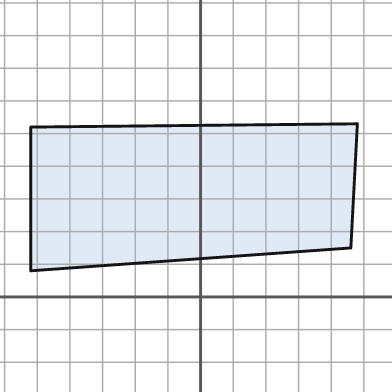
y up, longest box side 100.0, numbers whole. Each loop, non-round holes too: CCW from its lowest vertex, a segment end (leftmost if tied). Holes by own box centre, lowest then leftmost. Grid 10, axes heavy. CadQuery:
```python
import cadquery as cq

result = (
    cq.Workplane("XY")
    .moveTo(-52.0, 8.0)
    .lineTo(46.0, 15.0)
    .lineTo(48.0, 53.0)
    .lineTo(-52.0, 52.0)
    .close()
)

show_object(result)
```